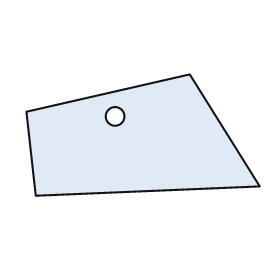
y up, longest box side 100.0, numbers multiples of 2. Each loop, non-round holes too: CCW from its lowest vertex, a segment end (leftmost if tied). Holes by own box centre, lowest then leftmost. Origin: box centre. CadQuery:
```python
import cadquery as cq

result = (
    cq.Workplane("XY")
    .moveTo(-46.0, -26.0)
    .lineTo(50.0, -22.0)
    .lineTo(20.0, 26.0)
    .lineTo(-50.0, 10.0)
    .close()
    .moveTo(-12.0, 8.0)
    .circle(4.0)
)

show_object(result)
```